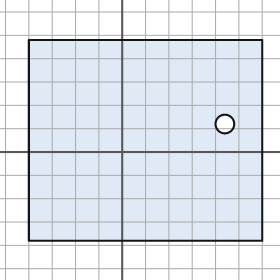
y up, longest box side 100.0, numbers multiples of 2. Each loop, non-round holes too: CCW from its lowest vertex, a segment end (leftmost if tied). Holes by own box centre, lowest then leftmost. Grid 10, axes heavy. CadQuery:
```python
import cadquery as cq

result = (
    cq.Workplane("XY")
    .moveTo(-40.0, -38.0)
    .lineTo(60.0, -38.0)
    .lineTo(60.0, 48.0)
    .lineTo(-40.0, 48.0)
    .close()
    .moveTo(44.0, 12.0)
    .circle(4.0)
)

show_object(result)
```